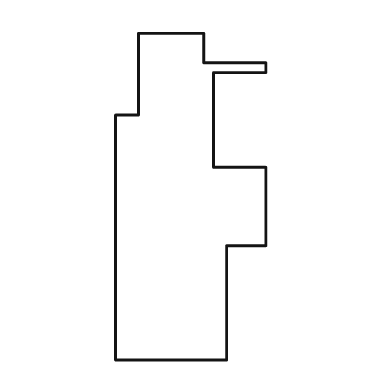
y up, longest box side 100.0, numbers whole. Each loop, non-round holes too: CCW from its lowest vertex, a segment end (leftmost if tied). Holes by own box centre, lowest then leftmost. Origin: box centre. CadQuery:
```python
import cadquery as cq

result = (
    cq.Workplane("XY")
    .moveTo(-23.0, -50.0)
    .lineTo(11.0, -50.0)
    .lineTo(11.0, -15.0)
    .lineTo(23.0, -15.0)
    .lineTo(23.0, 9.0)
    .lineTo(7.0, 9.0)
    .lineTo(7.0, 38.0)
    .lineTo(23.0, 38.0)
    .lineTo(23.0, 41.0)
    .lineTo(4.0, 41.0)
    .lineTo(4.0, 50.0)
    .lineTo(-16.0, 50.0)
    .lineTo(-16.0, 25.0)
    .lineTo(-23.0, 25.0)
    .close()
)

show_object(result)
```